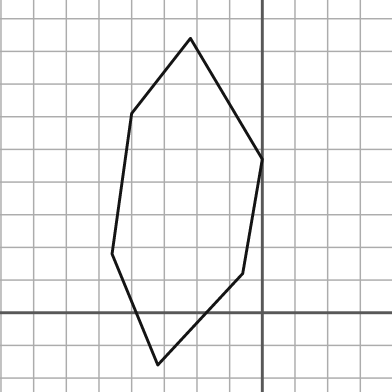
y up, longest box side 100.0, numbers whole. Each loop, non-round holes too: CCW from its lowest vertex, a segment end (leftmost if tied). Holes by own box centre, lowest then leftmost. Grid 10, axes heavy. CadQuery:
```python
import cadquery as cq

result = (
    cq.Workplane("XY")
    .moveTo(-32.0, -16.0)
    .lineTo(-6.0, 12.0)
    .lineTo(0.0, 47.0)
    .lineTo(-22.0, 84.0)
    .lineTo(-40.0, 61.0)
    .lineTo(-46.0, 18.0)
    .close()
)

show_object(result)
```